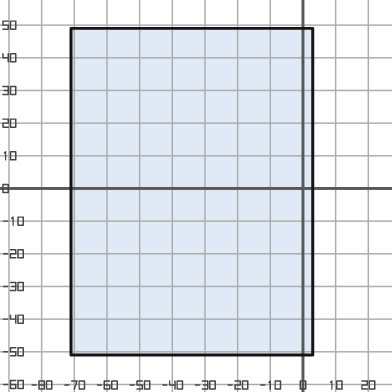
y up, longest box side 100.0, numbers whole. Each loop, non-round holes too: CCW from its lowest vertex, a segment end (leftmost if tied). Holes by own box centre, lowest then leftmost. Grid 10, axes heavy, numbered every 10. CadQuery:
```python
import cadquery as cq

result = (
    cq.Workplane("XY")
    .moveTo(-71.0, -51.0)
    .lineTo(3.0, -51.0)
    .lineTo(3.0, 49.0)
    .lineTo(-71.0, 49.0)
    .close()
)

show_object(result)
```